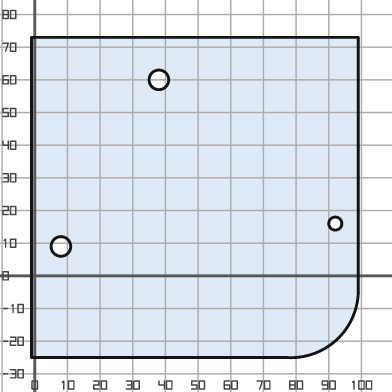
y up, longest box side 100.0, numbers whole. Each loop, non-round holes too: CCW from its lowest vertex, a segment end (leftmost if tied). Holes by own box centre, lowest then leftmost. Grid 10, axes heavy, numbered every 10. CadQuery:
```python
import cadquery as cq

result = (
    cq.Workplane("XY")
    .moveTo(-1.0, -25.0)
    .lineTo(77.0, -25.0)
    .threePointArc((93.0, -19.0), (99.0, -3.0))
    .lineTo(99.0, 73.0)
    .lineTo(-1.0, 73.0)
    .close()
    .moveTo(8.0, 9.0)
    .circle(3.0)
    .moveTo(92.0, 16.0)
    .circle(2.0)
    .moveTo(38.0, 60.0)
    .circle(3.0)
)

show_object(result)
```